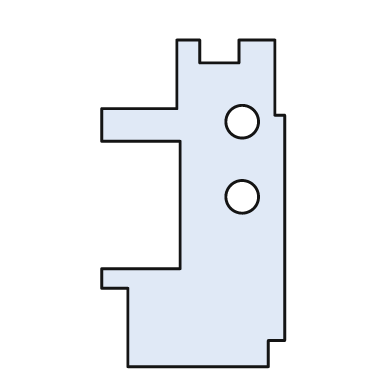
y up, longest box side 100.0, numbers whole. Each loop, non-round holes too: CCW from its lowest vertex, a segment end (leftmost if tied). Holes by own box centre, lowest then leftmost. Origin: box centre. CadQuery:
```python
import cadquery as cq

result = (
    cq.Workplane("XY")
    .moveTo(-20.0, -50.0)
    .lineTo(23.0, -50.0)
    .lineTo(23.0, -42.0)
    .lineTo(28.0, -42.0)
    .lineTo(28.0, 27.0)
    .lineTo(25.0, 27.0)
    .lineTo(25.0, 50.0)
    .lineTo(14.0, 50.0)
    .lineTo(14.0, 43.0)
    .lineTo(2.0, 43.0)
    .lineTo(2.0, 50.0)
    .lineTo(-5.0, 50.0)
    .lineTo(-5.0, 29.0)
    .lineTo(-28.0, 29.0)
    .lineTo(-28.0, 19.0)
    .lineTo(-4.0, 19.0)
    .lineTo(-4.0, -20.0)
    .lineTo(-28.0, -20.0)
    .lineTo(-28.0, -26.0)
    .lineTo(-20.0, -26.0)
    .close()
    .moveTo(15.0, 2.0)
    .circle(5.0)
    .moveTo(15.0, 25.0)
    .circle(5.0)
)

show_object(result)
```